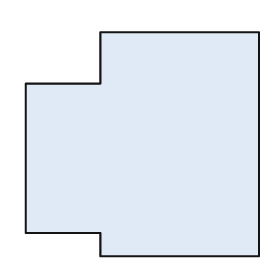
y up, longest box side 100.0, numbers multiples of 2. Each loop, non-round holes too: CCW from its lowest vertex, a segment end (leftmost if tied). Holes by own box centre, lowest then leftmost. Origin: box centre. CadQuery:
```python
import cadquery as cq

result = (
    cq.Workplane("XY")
    .moveTo(-18.0, -48.0)
    .lineTo(50.0, -48.0)
    .lineTo(50.0, 48.0)
    .lineTo(-18.0, 48.0)
    .lineTo(-18.0, 26.0)
    .lineTo(-50.0, 26.0)
    .lineTo(-50.0, -38.0)
    .lineTo(-18.0, -38.0)
    .close()
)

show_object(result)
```